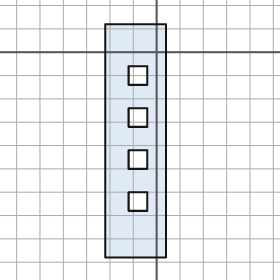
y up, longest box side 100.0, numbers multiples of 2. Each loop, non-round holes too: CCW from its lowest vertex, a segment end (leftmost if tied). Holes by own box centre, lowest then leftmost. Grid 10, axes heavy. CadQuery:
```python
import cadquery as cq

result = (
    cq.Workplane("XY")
    .moveTo(-22.0, -88.0)
    .lineTo(4.0, -88.0)
    .lineTo(4.0, 12.0)
    .lineTo(-22.0, 12.0)
    .close()
    .moveTo(-12.0, -68.0)
    .lineTo(-4.0, -68.0)
    .lineTo(-4.0, -60.0)
    .lineTo(-12.0, -60.0)
    .close()
    .moveTo(-12.0, -50.0)
    .lineTo(-4.0, -50.0)
    .lineTo(-4.0, -42.0)
    .lineTo(-12.0, -42.0)
    .close()
    .moveTo(-12.0, -32.0)
    .lineTo(-4.0, -32.0)
    .lineTo(-4.0, -24.0)
    .lineTo(-12.0, -24.0)
    .close()
    .moveTo(-12.0, -14.0)
    .lineTo(-4.0, -14.0)
    .lineTo(-4.0, -6.0)
    .lineTo(-12.0, -6.0)
    .close()
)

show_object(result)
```